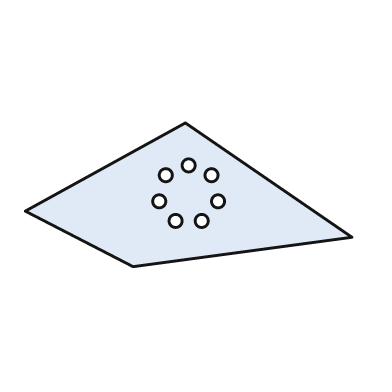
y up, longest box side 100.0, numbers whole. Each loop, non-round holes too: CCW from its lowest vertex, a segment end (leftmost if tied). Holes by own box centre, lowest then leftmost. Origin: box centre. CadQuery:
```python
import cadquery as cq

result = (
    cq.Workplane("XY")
    .moveTo(-17.0, -22.0)
    .lineTo(50.0, -13.0)
    .lineTo(-1.0, 22.0)
    .lineTo(-50.0, -5.0)
    .close()
    .moveTo(-4.0, -8.0)
    .circle(2.0)
    .moveTo(4.0, -8.0)
    .circle(2.0)
    .moveTo(-9.0, -2.0)
    .circle(2.0)
    .moveTo(9.0, -2.0)
    .circle(2.0)
    .moveTo(-7.0, 6.0)
    .circle(2.0)
    .moveTo(7.0, 6.0)
    .circle(2.0)
    .moveTo(0.0, 9.0)
    .circle(2.0)
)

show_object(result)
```